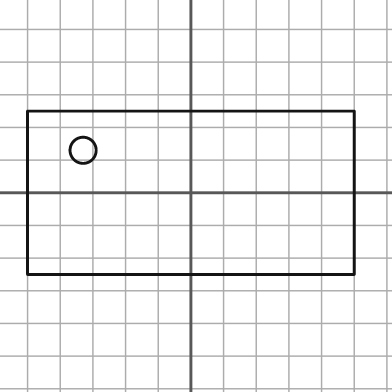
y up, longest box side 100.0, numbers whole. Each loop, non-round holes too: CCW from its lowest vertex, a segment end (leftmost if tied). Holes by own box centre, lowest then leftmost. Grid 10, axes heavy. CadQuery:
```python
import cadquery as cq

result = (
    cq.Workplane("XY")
    .moveTo(-50.0, -25.0)
    .lineTo(50.0, -25.0)
    .lineTo(50.0, 25.0)
    .lineTo(-50.0, 25.0)
    .close()
    .moveTo(-33.0, 13.0)
    .circle(4.0)
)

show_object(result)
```